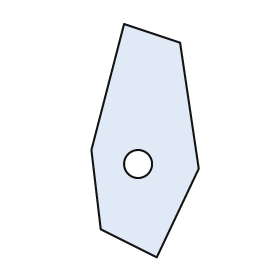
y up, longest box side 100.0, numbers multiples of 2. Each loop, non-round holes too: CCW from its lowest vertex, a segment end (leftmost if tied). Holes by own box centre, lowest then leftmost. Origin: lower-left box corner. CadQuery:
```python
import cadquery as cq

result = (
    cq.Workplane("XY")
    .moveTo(28.0, 0.0)
    .lineTo(46.0, 38.0)
    .lineTo(38.0, 92.0)
    .lineTo(14.0, 100.0)
    .lineTo(0.0, 46.0)
    .lineTo(4.0, 12.0)
    .close()
    .moveTo(20.0, 40.0)
    .circle(6.0)
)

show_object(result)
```